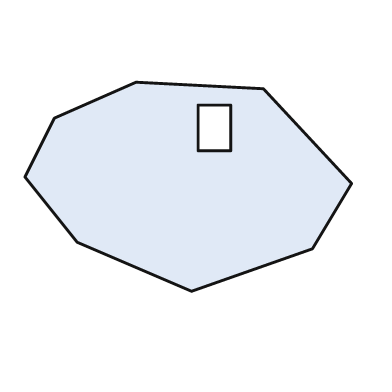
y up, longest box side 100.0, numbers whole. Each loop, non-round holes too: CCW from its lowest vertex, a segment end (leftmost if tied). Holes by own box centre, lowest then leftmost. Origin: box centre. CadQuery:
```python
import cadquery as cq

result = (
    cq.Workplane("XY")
    .moveTo(1.0, -32.0)
    .lineTo(38.0, -19.0)
    .lineTo(50.0, 1.0)
    .lineTo(23.0, 30.0)
    .lineTo(-16.0, 32.0)
    .lineTo(-41.0, 21.0)
    .lineTo(-50.0, 3.0)
    .lineTo(-34.0, -17.0)
    .close()
    .moveTo(3.0, 11.0)
    .lineTo(13.0, 11.0)
    .lineTo(13.0, 25.0)
    .lineTo(3.0, 25.0)
    .close()
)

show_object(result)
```